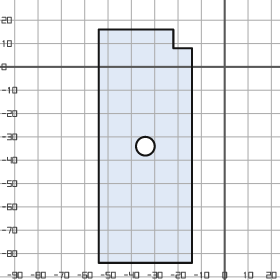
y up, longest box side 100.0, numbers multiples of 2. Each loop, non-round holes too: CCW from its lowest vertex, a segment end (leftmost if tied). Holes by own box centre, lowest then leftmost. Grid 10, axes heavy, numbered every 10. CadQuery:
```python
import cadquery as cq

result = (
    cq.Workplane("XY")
    .moveTo(-54.0, -84.0)
    .lineTo(-14.0, -84.0)
    .lineTo(-14.0, 8.0)
    .lineTo(-22.0, 8.0)
    .lineTo(-22.0, 16.0)
    .lineTo(-54.0, 16.0)
    .close()
    .moveTo(-34.0, -34.0)
    .circle(4.0)
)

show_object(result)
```